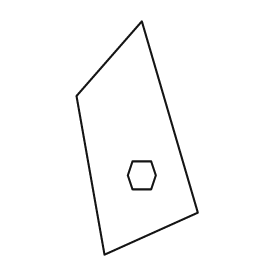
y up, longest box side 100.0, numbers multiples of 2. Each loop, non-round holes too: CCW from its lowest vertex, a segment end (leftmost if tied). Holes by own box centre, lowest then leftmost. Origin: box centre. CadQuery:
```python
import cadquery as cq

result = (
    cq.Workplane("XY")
    .moveTo(-14.0, -50.0)
    .lineTo(26.0, -32.0)
    .lineTo(2.0, 50.0)
    .lineTo(-26.0, 18.0)
    .close()
    .moveTo(-2.0, -22.0)
    .lineTo(6.0, -22.0)
    .lineTo(8.0, -16.0)
    .lineTo(6.0, -10.0)
    .lineTo(-2.0, -10.0)
    .lineTo(-4.0, -16.0)
    .close()
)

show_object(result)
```